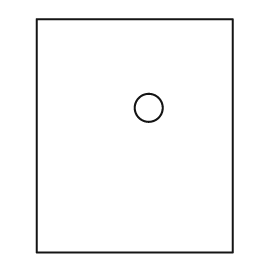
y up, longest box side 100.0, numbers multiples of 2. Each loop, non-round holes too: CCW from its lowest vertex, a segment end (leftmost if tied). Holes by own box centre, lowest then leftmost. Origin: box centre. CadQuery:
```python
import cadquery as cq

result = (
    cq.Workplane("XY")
    .moveTo(-42.0, -50.0)
    .lineTo(42.0, -50.0)
    .lineTo(42.0, 50.0)
    .lineTo(-42.0, 50.0)
    .close()
    .moveTo(6.0, 12.0)
    .circle(6.0)
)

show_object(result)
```